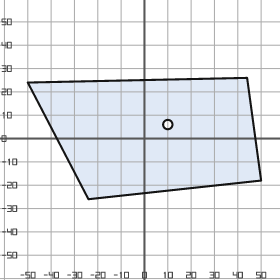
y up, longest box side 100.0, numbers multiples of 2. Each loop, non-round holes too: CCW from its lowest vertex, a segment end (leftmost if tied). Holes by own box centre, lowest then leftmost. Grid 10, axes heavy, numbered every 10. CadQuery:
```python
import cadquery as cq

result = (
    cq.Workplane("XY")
    .moveTo(-24.0, -26.0)
    .lineTo(50.0, -18.0)
    .lineTo(44.0, 26.0)
    .lineTo(-50.0, 24.0)
    .close()
    .moveTo(10.0, 6.0)
    .circle(2.0)
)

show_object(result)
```